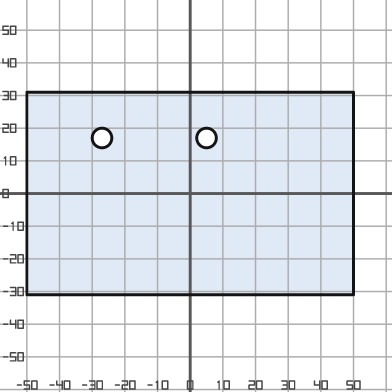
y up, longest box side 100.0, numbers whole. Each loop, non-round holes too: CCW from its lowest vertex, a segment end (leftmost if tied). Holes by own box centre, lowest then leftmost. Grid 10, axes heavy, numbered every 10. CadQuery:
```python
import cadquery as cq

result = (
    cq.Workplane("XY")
    .moveTo(-50.0, -31.0)
    .lineTo(50.0, -31.0)
    .lineTo(50.0, 31.0)
    .lineTo(-50.0, 31.0)
    .close()
    .moveTo(-27.0, 17.0)
    .circle(3.0)
    .moveTo(5.0, 17.0)
    .circle(3.0)
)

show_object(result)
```